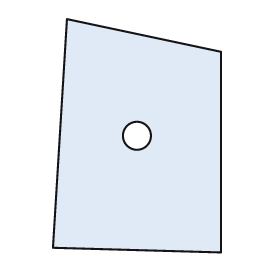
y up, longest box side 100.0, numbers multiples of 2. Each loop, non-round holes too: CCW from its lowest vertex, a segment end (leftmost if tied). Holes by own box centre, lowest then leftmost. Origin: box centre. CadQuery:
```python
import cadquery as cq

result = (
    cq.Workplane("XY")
    .moveTo(36.0, -50.0)
    .lineTo(36.0, 36.0)
    .lineTo(-30.0, 50.0)
    .lineTo(-36.0, -48.0)
    .close()
    .moveTo(0.0, 0.0)
    .circle(6.0)
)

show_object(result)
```